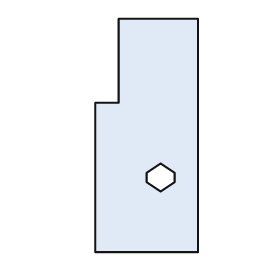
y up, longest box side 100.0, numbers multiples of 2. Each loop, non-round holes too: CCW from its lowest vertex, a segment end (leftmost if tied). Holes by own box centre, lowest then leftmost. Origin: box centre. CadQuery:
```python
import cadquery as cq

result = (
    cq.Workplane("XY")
    .moveTo(-22.0, -50.0)
    .lineTo(22.0, -50.0)
    .lineTo(22.0, 50.0)
    .lineTo(-12.0, 50.0)
    .lineTo(-12.0, 14.0)
    .lineTo(-22.0, 14.0)
    .close()
    .moveTo(6.0, -24.0)
    .lineTo(12.0, -20.0)
    .lineTo(12.0, -16.0)
    .lineTo(6.0, -12.0)
    .lineTo(0.0, -16.0)
    .lineTo(0.0, -20.0)
    .close()
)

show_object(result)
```